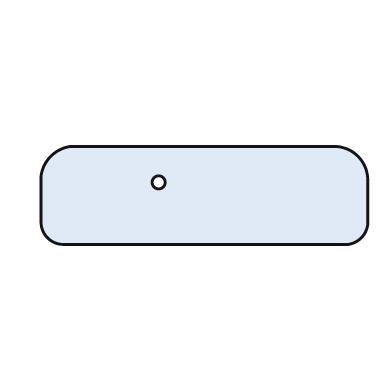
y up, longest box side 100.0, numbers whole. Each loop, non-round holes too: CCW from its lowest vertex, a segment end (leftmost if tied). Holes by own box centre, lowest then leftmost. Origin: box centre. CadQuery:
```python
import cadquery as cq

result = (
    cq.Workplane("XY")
    .moveTo(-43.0, -15.0)
    .lineTo(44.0, -15.0)
    .threePointArc((48.0, -13.0), (50.0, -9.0))
    .lineTo(50.0, 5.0)
    .threePointArc((47.0, 12.0), (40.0, 15.0))
    .lineTo(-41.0, 15.0)
    .threePointArc((-47.0, 12.0), (-50.0, 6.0))
    .lineTo(-50.0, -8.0)
    .threePointArc((-48.0, -13.0), (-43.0, -15.0))
    .close()
    .moveTo(-14.0, 4.0)
    .circle(2.0)
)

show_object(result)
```